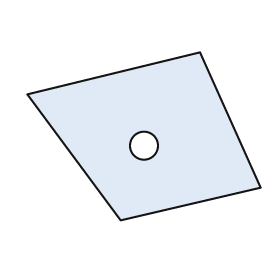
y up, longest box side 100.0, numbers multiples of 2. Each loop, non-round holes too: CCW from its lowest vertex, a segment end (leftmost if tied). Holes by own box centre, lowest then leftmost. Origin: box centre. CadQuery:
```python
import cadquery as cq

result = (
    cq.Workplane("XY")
    .moveTo(-10.0, -36.0)
    .lineTo(50.0, -22.0)
    .lineTo(24.0, 36.0)
    .lineTo(-50.0, 18.0)
    .close()
    .moveTo(0.0, -4.0)
    .circle(6.0)
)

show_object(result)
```